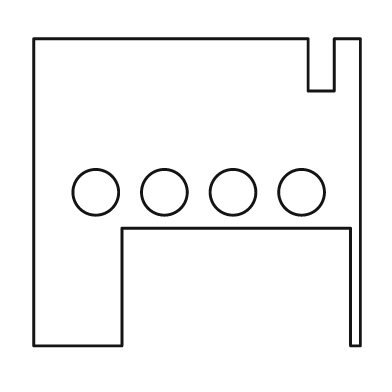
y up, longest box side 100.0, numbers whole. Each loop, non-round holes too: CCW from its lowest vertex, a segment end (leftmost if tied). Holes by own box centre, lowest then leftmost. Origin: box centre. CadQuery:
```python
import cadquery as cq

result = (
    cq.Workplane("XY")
    .moveTo(-50.0, -47.0)
    .lineTo(-23.0, -47.0)
    .lineTo(-23.0, -11.0)
    .lineTo(47.0, -11.0)
    .lineTo(47.0, -47.0)
    .lineTo(50.0, -47.0)
    .lineTo(50.0, 47.0)
    .lineTo(42.0, 47.0)
    .lineTo(42.0, 31.0)
    .lineTo(34.0, 31.0)
    .lineTo(34.0, 47.0)
    .lineTo(-50.0, 47.0)
    .close()
    .moveTo(-31.0, 0.0)
    .circle(7.0)
    .moveTo(-10.0, 0.0)
    .circle(7.0)
    .moveTo(11.0, 0.0)
    .circle(7.0)
    .moveTo(32.0, 0.0)
    .circle(7.0)
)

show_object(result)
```